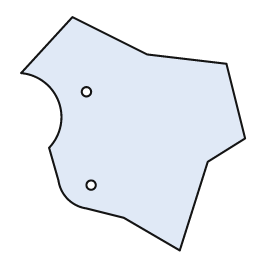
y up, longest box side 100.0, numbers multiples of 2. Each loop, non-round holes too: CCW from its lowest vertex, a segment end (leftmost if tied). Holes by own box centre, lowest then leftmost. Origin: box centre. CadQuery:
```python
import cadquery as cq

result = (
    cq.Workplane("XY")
    .moveTo(20.0, -50.0)
    .lineTo(32.0, -12.0)
    .lineTo(48.0, -2.0)
    .lineTo(40.0, 30.0)
    .lineTo(6.0, 34.0)
    .lineTo(-26.0, 50.0)
    .lineTo(-48.0, 26.0)
    .threePointArc((-32.0, 14.0), (-36.0, -6.0))
    .lineTo(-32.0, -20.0)
    .threePointArc((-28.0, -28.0), (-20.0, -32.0))
    .lineTo(-4.0, -36.0)
    .close()
    .moveTo(-18.0, -22.0)
    .circle(2.0)
    .moveTo(-20.0, 18.0)
    .circle(2.0)
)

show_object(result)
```